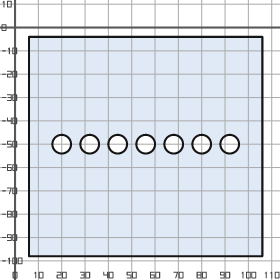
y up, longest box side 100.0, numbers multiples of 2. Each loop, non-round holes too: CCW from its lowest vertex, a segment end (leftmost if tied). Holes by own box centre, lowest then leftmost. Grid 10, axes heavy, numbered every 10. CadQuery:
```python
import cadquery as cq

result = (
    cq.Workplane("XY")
    .moveTo(6.0, -98.0)
    .lineTo(106.0, -98.0)
    .lineTo(106.0, -4.0)
    .lineTo(6.0, -4.0)
    .close()
    .moveTo(20.0, -50.0)
    .circle(4.0)
    .moveTo(32.0, -50.0)
    .circle(4.0)
    .moveTo(44.0, -50.0)
    .circle(4.0)
    .moveTo(56.0, -50.0)
    .circle(4.0)
    .moveTo(68.0, -50.0)
    .circle(4.0)
    .moveTo(80.0, -50.0)
    .circle(4.0)
    .moveTo(92.0, -50.0)
    .circle(4.0)
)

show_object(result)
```